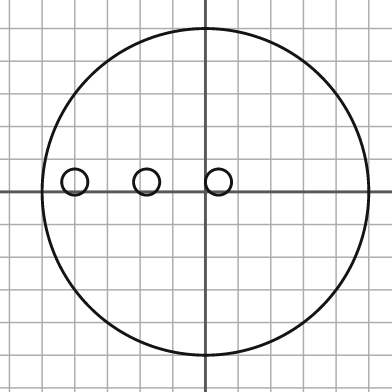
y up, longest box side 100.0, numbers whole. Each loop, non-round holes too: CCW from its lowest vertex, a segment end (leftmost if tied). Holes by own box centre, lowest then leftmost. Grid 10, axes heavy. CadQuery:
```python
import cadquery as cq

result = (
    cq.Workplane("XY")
    .moveTo(0.0, 0.0)
    .circle(50.0)
    .moveTo(-40.0, 3.0)
    .circle(4.0)
    .moveTo(-18.0, 3.0)
    .circle(4.0)
    .moveTo(4.0, 3.0)
    .circle(4.0)
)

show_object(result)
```